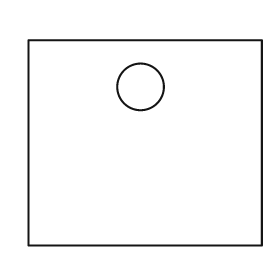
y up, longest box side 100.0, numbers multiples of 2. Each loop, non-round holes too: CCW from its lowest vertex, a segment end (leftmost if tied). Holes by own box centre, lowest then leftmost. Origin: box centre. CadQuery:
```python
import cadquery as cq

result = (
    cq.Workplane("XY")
    .moveTo(-50.0, -44.0)
    .lineTo(50.0, -44.0)
    .lineTo(50.0, 44.0)
    .lineTo(-50.0, 44.0)
    .close()
    .moveTo(-2.0, 24.0)
    .circle(10.0)
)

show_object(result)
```